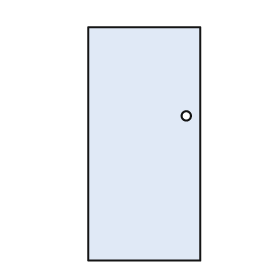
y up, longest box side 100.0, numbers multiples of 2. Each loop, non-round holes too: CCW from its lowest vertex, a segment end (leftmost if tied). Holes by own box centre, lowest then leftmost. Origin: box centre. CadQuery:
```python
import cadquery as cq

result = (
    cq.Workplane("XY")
    .moveTo(-24.0, -50.0)
    .lineTo(24.0, -50.0)
    .lineTo(24.0, 50.0)
    .lineTo(-24.0, 50.0)
    .close()
    .moveTo(18.0, 12.0)
    .circle(2.0)
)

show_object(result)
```